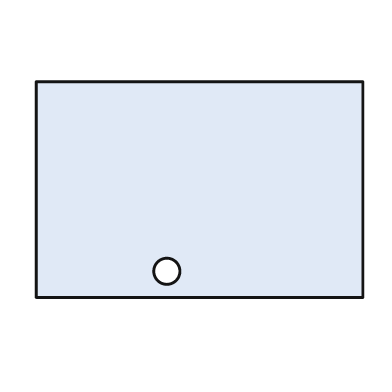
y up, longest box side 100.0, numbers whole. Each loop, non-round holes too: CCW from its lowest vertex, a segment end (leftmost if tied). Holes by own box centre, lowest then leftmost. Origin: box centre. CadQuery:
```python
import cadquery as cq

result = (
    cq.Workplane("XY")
    .moveTo(-50.0, -33.0)
    .lineTo(50.0, -33.0)
    .lineTo(50.0, 33.0)
    .lineTo(-50.0, 33.0)
    .close()
    .moveTo(-10.0, -25.0)
    .circle(4.0)
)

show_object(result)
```